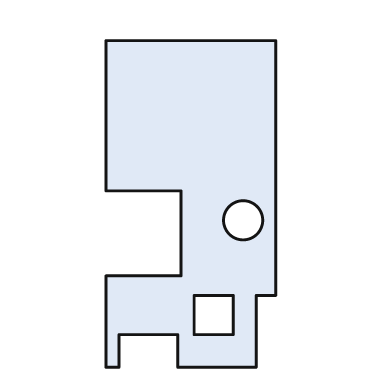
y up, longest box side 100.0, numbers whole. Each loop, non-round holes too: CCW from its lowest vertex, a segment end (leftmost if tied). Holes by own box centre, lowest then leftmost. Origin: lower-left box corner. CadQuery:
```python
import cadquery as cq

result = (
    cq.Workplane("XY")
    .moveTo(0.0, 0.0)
    .lineTo(4.0, 0.0)
    .lineTo(4.0, 10.0)
    .lineTo(22.0, 10.0)
    .lineTo(22.0, 0.0)
    .lineTo(46.0, 0.0)
    .lineTo(46.0, 22.0)
    .lineTo(52.0, 22.0)
    .lineTo(52.0, 100.0)
    .lineTo(0.0, 100.0)
    .lineTo(0.0, 54.0)
    .lineTo(23.0, 54.0)
    .lineTo(23.0, 28.0)
    .lineTo(0.0, 28.0)
    .close()
    .moveTo(27.0, 10.0)
    .lineTo(39.0, 10.0)
    .lineTo(39.0, 22.0)
    .lineTo(27.0, 22.0)
    .close()
    .moveTo(42.0, 45.0)
    .circle(6.0)
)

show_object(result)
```